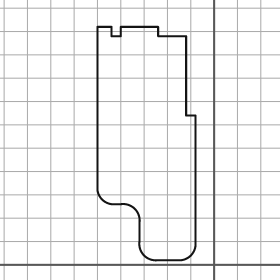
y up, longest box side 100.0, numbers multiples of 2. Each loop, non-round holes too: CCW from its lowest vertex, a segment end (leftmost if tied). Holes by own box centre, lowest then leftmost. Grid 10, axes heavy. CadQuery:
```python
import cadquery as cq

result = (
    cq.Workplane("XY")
    .moveTo(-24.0, 2.0)
    .lineTo(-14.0, 2.0)
    .threePointArc((-10.0, 4.0), (-8.0, 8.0))
    .lineTo(-8.0, 64.0)
    .lineTo(-12.0, 64.0)
    .lineTo(-12.0, 98.0)
    .lineTo(-24.0, 98.0)
    .lineTo(-24.0, 102.0)
    .lineTo(-40.0, 102.0)
    .lineTo(-40.0, 98.0)
    .lineTo(-44.0, 98.0)
    .lineTo(-44.0, 102.0)
    .lineTo(-50.0, 102.0)
    .lineTo(-50.0, 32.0)
    .threePointArc((-48.0, 28.0), (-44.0, 26.0))
    .lineTo(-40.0, 26.0)
    .threePointArc((-34.0, 24.0), (-32.0, 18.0))
    .lineTo(-32.0, 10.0)
    .threePointArc((-30.0, 4.0), (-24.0, 2.0))
    .close()
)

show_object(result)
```